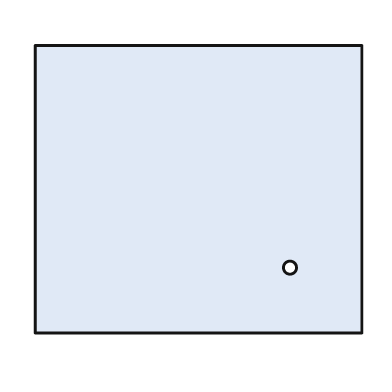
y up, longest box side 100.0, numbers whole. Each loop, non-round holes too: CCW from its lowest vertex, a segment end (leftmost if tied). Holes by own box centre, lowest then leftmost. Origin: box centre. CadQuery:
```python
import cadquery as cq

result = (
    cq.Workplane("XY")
    .moveTo(-50.0, -44.0)
    .lineTo(50.0, -44.0)
    .lineTo(50.0, 44.0)
    .lineTo(-50.0, 44.0)
    .close()
    .moveTo(28.0, -24.0)
    .circle(2.0)
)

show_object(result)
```